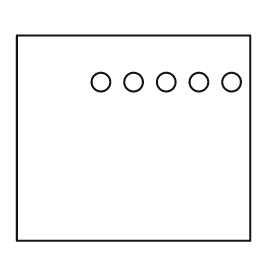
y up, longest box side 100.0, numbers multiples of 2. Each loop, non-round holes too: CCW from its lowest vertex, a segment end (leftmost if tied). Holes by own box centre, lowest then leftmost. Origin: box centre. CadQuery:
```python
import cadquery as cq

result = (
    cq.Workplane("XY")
    .moveTo(-50.0, -44.0)
    .lineTo(50.0, -44.0)
    .lineTo(50.0, 44.0)
    .lineTo(-50.0, 44.0)
    .close()
    .moveTo(-14.0, 24.0)
    .circle(4.0)
    .moveTo(0.0, 24.0)
    .circle(4.0)
    .moveTo(14.0, 24.0)
    .circle(4.0)
    .moveTo(28.0, 24.0)
    .circle(4.0)
    .moveTo(42.0, 24.0)
    .circle(4.0)
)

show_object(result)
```